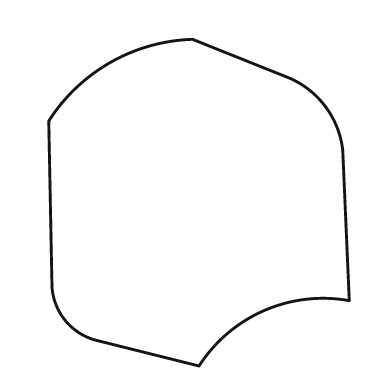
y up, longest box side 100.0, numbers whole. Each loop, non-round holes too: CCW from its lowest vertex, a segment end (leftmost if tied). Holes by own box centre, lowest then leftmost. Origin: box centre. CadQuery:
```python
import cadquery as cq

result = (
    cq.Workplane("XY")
    .moveTo(0.0, -50.0)
    .threePointArc((20.0, -33.0), (46.0, -30.0))
    .lineTo(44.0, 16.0)
    .threePointArc((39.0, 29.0), (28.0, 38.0))
    .lineTo(-2.0, 50.0)
    .threePointArc((-27.0, 43.0), (-46.0, 25.0))
    .lineTo(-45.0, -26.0)
    .threePointArc((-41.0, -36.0), (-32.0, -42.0))
    .close()
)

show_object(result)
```